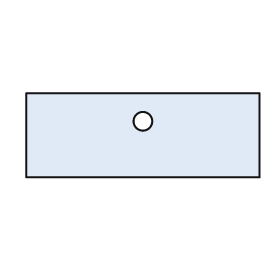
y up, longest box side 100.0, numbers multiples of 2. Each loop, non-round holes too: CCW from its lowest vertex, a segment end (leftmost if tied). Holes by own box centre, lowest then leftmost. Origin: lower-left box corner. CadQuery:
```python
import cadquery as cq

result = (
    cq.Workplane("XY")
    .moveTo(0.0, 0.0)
    .lineTo(100.0, 0.0)
    .lineTo(100.0, 36.0)
    .lineTo(0.0, 36.0)
    .close()
    .moveTo(50.0, 24.0)
    .circle(4.0)
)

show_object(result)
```